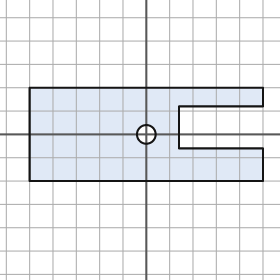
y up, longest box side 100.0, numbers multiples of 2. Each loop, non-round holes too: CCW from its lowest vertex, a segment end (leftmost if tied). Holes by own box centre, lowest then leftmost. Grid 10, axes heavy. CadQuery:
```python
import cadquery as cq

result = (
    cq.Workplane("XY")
    .moveTo(-50.0, -20.0)
    .lineTo(50.0, -20.0)
    .lineTo(50.0, -6.0)
    .lineTo(14.0, -6.0)
    .lineTo(14.0, 12.0)
    .lineTo(50.0, 12.0)
    .lineTo(50.0, 20.0)
    .lineTo(-50.0, 20.0)
    .close()
    .moveTo(0.0, 0.0)
    .circle(4.0)
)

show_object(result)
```